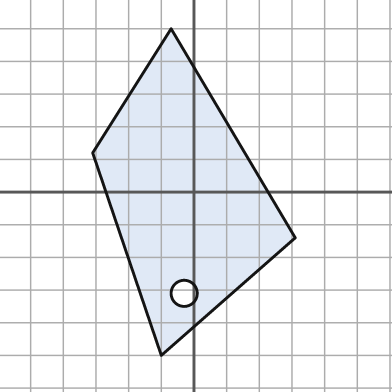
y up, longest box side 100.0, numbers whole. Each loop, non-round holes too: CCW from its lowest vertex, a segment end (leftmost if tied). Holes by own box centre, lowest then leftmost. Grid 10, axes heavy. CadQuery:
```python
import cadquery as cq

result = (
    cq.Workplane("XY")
    .moveTo(-10.0, -50.0)
    .lineTo(31.0, -14.0)
    .lineTo(-7.0, 50.0)
    .lineTo(-31.0, 12.0)
    .close()
    .moveTo(-3.0, -31.0)
    .circle(4.0)
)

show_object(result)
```